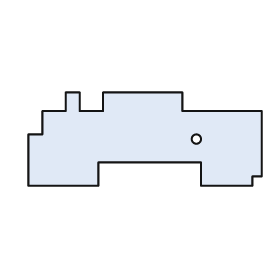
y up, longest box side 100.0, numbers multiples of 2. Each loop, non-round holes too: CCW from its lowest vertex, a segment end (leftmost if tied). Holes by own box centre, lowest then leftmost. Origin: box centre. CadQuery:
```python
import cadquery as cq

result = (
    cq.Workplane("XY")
    .moveTo(-50.0, -20.0)
    .lineTo(-20.0, -20.0)
    .lineTo(-20.0, -10.0)
    .lineTo(24.0, -10.0)
    .lineTo(24.0, -20.0)
    .lineTo(46.0, -20.0)
    .lineTo(46.0, -16.0)
    .lineTo(50.0, -16.0)
    .lineTo(50.0, 12.0)
    .lineTo(16.0, 12.0)
    .lineTo(16.0, 20.0)
    .lineTo(-18.0, 20.0)
    .lineTo(-18.0, 12.0)
    .lineTo(-28.0, 12.0)
    .lineTo(-28.0, 20.0)
    .lineTo(-34.0, 20.0)
    .lineTo(-34.0, 12.0)
    .lineTo(-44.0, 12.0)
    .lineTo(-44.0, 2.0)
    .lineTo(-50.0, 2.0)
    .close()
    .moveTo(22.0, 0.0)
    .circle(2.0)
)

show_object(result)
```